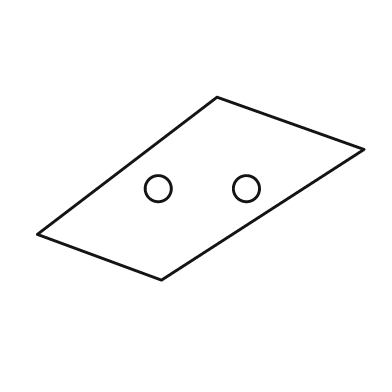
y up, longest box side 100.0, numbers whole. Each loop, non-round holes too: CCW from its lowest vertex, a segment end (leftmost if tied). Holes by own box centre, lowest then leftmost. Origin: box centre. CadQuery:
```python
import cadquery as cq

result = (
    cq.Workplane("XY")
    .moveTo(-12.0, -28.0)
    .lineTo(50.0, 12.0)
    .lineTo(5.0, 28.0)
    .lineTo(-50.0, -14.0)
    .close()
    .moveTo(-13.0, 0.0)
    .circle(4.0)
    .moveTo(14.0, 0.0)
    .circle(4.0)
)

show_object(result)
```